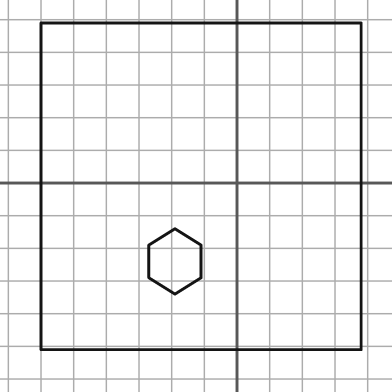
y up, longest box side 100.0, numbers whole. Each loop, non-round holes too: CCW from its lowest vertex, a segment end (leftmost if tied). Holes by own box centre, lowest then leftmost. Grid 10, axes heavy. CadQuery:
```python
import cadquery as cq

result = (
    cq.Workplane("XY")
    .moveTo(-60.0, -51.0)
    .lineTo(38.0, -51.0)
    .lineTo(38.0, 49.0)
    .lineTo(-60.0, 49.0)
    .close()
    .moveTo(-19.0, -34.0)
    .lineTo(-11.0, -29.0)
    .lineTo(-11.0, -19.0)
    .lineTo(-19.0, -14.0)
    .lineTo(-27.0, -19.0)
    .lineTo(-27.0, -29.0)
    .close()
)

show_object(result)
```